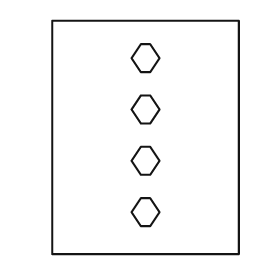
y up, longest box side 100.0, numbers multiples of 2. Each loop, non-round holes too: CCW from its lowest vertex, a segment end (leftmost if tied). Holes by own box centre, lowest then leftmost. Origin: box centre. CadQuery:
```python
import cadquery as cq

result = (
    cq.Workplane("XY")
    .moveTo(-40.0, -50.0)
    .lineTo(40.0, -50.0)
    .lineTo(40.0, 50.0)
    .lineTo(-40.0, 50.0)
    .close()
    .moveTo(-2.0, -38.0)
    .lineTo(2.0, -38.0)
    .lineTo(6.0, -32.0)
    .lineTo(2.0, -26.0)
    .lineTo(-2.0, -26.0)
    .lineTo(-6.0, -32.0)
    .close()
    .moveTo(-2.0, -16.0)
    .lineTo(2.0, -16.0)
    .lineTo(6.0, -10.0)
    .lineTo(2.0, -4.0)
    .lineTo(-2.0, -4.0)
    .lineTo(-6.0, -10.0)
    .close()
    .moveTo(-2.0, 6.0)
    .lineTo(2.0, 6.0)
    .lineTo(6.0, 12.0)
    .lineTo(2.0, 18.0)
    .lineTo(-2.0, 18.0)
    .lineTo(-6.0, 12.0)
    .close()
    .moveTo(-2.0, 28.0)
    .lineTo(2.0, 28.0)
    .lineTo(6.0, 34.0)
    .lineTo(2.0, 40.0)
    .lineTo(-2.0, 40.0)
    .lineTo(-6.0, 34.0)
    .close()
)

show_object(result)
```